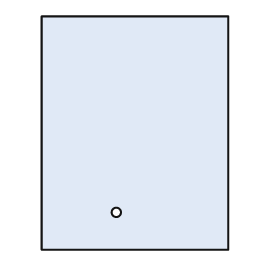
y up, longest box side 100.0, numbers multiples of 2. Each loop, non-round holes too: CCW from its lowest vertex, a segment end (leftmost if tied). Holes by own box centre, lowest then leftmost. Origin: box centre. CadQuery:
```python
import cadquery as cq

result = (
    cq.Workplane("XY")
    .moveTo(-40.0, -50.0)
    .lineTo(40.0, -50.0)
    .lineTo(40.0, 50.0)
    .lineTo(-40.0, 50.0)
    .close()
    .moveTo(-8.0, -34.0)
    .circle(2.0)
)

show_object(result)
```